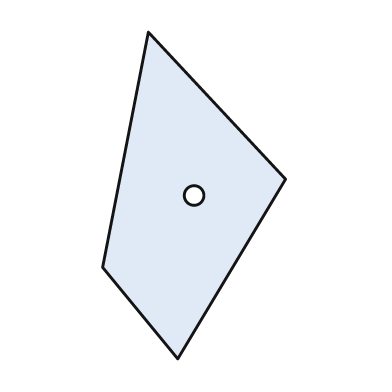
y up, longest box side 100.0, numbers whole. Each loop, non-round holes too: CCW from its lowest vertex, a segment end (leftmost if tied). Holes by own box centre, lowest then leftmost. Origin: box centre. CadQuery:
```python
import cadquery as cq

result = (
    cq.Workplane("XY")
    .moveTo(-5.0, -50.0)
    .lineTo(28.0, 5.0)
    .lineTo(-14.0, 50.0)
    .lineTo(-28.0, -22.0)
    .close()
    .moveTo(0.0, 0.0)
    .circle(3.0)
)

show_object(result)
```